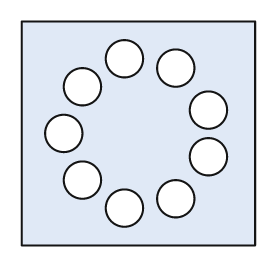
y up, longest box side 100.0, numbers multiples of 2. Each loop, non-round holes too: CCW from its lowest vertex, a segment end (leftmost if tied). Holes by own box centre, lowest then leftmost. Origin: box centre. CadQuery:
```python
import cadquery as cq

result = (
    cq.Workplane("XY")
    .moveTo(-50.0, -48.0)
    .lineTo(50.0, -48.0)
    .lineTo(50.0, 48.0)
    .lineTo(-50.0, 48.0)
    .close()
    .moveTo(-6.0, -32.0)
    .circle(8.0)
    .moveTo(16.0, -28.0)
    .circle(8.0)
    .moveTo(-24.0, -20.0)
    .circle(8.0)
    .moveTo(30.0, -10.0)
    .circle(8.0)
    .moveTo(-32.0, 0.0)
    .circle(8.0)
    .moveTo(30.0, 10.0)
    .circle(8.0)
    .moveTo(-24.0, 20.0)
    .circle(8.0)
    .moveTo(16.0, 28.0)
    .circle(8.0)
    .moveTo(-6.0, 32.0)
    .circle(8.0)
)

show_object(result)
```